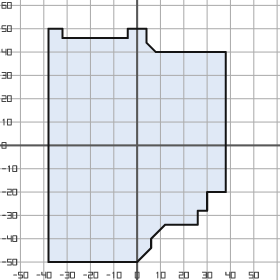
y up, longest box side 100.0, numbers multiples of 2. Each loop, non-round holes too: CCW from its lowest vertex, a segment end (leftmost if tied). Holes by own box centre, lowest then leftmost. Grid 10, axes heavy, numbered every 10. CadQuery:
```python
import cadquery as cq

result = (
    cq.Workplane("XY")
    .moveTo(-38.0, -50.0)
    .lineTo(0.0, -50.0)
    .lineTo(6.0, -44.0)
    .lineTo(6.0, -40.0)
    .lineTo(12.0, -34.0)
    .lineTo(26.0, -34.0)
    .lineTo(26.0, -28.0)
    .lineTo(30.0, -28.0)
    .lineTo(30.0, -20.0)
    .lineTo(38.0, -20.0)
    .lineTo(38.0, 40.0)
    .lineTo(8.0, 40.0)
    .lineTo(4.0, 44.0)
    .lineTo(4.0, 50.0)
    .lineTo(-4.0, 50.0)
    .lineTo(-4.0, 46.0)
    .lineTo(-32.0, 46.0)
    .lineTo(-32.0, 50.0)
    .lineTo(-38.0, 50.0)
    .close()
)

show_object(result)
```